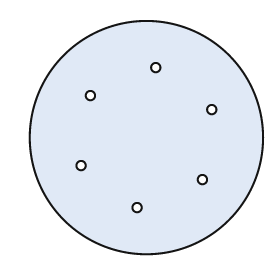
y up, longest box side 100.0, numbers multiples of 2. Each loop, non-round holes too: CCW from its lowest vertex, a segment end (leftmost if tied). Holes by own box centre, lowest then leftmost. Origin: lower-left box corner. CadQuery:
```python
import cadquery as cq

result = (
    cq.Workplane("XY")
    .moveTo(50.0, 50.0)
    .circle(50.0)
    .moveTo(46.0, 20.0)
    .circle(2.0)
    .moveTo(74.0, 32.0)
    .circle(2.0)
    .moveTo(22.0, 38.0)
    .circle(2.0)
    .moveTo(78.0, 62.0)
    .circle(2.0)
    .moveTo(26.0, 68.0)
    .circle(2.0)
    .moveTo(54.0, 80.0)
    .circle(2.0)
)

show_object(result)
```